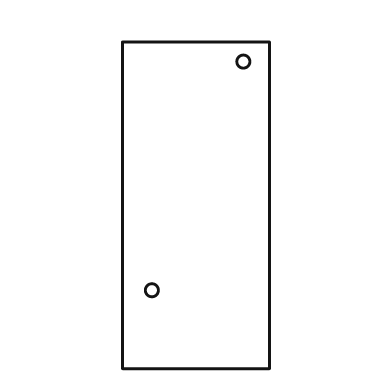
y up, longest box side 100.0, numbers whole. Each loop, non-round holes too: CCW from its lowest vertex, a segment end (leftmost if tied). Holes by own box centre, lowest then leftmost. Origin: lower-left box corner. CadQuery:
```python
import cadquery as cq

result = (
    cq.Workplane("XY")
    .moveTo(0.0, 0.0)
    .lineTo(45.0, 0.0)
    .lineTo(45.0, 100.0)
    .lineTo(0.0, 100.0)
    .close()
    .moveTo(9.0, 24.0)
    .circle(2.0)
    .moveTo(37.0, 94.0)
    .circle(2.0)
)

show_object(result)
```